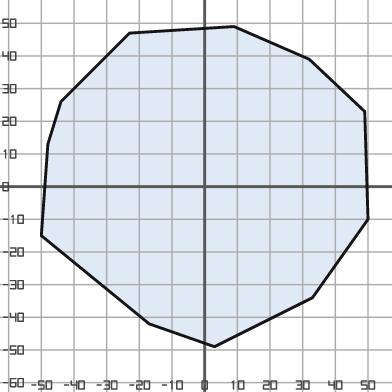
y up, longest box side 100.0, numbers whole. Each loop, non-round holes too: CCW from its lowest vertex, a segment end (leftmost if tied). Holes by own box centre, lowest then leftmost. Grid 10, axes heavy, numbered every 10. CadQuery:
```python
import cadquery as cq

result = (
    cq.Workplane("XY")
    .moveTo(3.0, -49.0)
    .lineTo(33.0, -34.0)
    .lineTo(50.0, -10.0)
    .lineTo(49.0, 23.0)
    .lineTo(32.0, 39.0)
    .lineTo(9.0, 49.0)
    .lineTo(-23.0, 47.0)
    .lineTo(-44.0, 26.0)
    .lineTo(-48.0, 13.0)
    .lineTo(-50.0, -15.0)
    .lineTo(-17.0, -42.0)
    .close()
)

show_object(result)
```